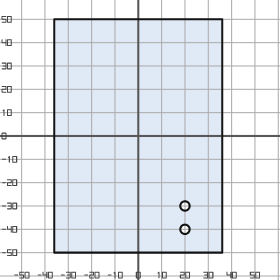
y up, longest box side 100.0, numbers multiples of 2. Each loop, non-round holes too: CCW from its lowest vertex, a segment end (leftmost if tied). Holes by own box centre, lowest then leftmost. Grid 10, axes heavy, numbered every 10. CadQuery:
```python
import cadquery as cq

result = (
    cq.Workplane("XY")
    .moveTo(-36.0, -50.0)
    .lineTo(36.0, -50.0)
    .lineTo(36.0, 50.0)
    .lineTo(-36.0, 50.0)
    .close()
    .moveTo(20.0, -40.0)
    .circle(2.0)
    .moveTo(20.0, -30.0)
    .circle(2.0)
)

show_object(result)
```